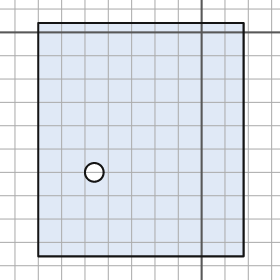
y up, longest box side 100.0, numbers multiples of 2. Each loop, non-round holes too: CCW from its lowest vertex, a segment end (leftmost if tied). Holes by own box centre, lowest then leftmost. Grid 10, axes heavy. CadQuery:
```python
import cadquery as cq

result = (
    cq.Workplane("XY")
    .moveTo(-70.0, -96.0)
    .lineTo(18.0, -96.0)
    .lineTo(18.0, 4.0)
    .lineTo(-70.0, 4.0)
    .close()
    .moveTo(-46.0, -60.0)
    .circle(4.0)
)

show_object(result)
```